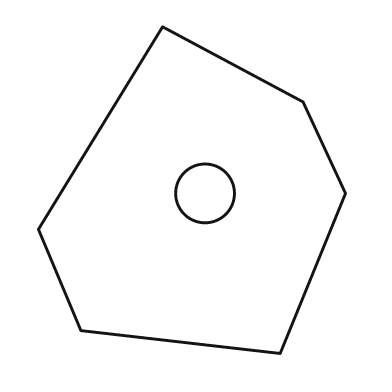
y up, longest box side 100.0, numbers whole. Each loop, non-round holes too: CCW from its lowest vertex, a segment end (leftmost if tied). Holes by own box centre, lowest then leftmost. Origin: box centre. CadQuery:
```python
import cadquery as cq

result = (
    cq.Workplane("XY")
    .moveTo(27.0, -50.0)
    .lineTo(47.0, -1.0)
    .lineTo(34.0, 27.0)
    .lineTo(-9.0, 50.0)
    .lineTo(-47.0, -12.0)
    .lineTo(-34.0, -43.0)
    .close()
    .moveTo(4.0, -1.0)
    .circle(9.0)
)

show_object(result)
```